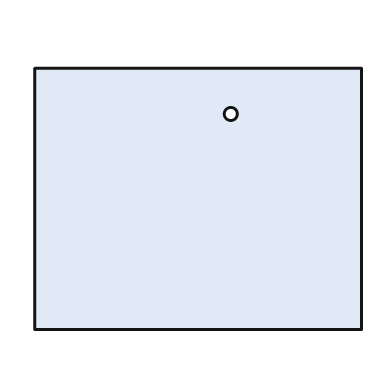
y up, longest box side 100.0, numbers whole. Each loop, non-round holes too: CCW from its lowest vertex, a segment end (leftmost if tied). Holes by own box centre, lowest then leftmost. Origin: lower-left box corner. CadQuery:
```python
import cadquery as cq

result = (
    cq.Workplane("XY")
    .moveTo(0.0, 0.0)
    .lineTo(100.0, 0.0)
    .lineTo(100.0, 80.0)
    .lineTo(0.0, 80.0)
    .close()
    .moveTo(60.0, 66.0)
    .circle(2.0)
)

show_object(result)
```